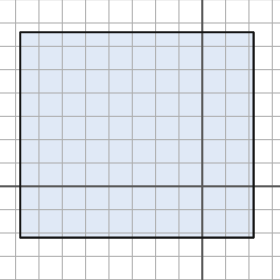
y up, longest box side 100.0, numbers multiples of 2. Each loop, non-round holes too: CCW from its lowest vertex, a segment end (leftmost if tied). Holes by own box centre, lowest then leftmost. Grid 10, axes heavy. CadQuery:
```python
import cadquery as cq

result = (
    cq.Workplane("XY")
    .moveTo(-78.0, -22.0)
    .lineTo(22.0, -22.0)
    .lineTo(22.0, 66.0)
    .lineTo(-78.0, 66.0)
    .close()
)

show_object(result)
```